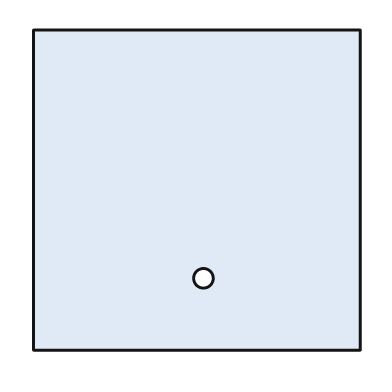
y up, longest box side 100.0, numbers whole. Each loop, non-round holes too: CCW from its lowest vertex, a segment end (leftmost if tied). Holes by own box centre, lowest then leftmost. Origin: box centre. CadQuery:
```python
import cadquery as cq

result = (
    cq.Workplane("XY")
    .moveTo(-50.0, -49.0)
    .lineTo(50.0, -49.0)
    .lineTo(50.0, 49.0)
    .lineTo(-50.0, 49.0)
    .close()
    .moveTo(2.0, -27.0)
    .circle(3.0)
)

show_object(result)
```